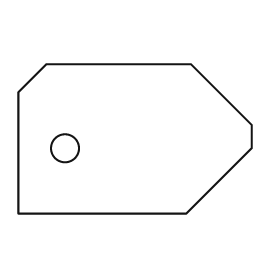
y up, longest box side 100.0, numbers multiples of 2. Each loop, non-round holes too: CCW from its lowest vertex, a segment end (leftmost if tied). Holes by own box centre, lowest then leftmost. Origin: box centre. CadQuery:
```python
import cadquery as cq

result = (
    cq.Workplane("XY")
    .moveTo(-50.0, -32.0)
    .lineTo(22.0, -32.0)
    .lineTo(50.0, -4.0)
    .lineTo(50.0, 6.0)
    .lineTo(24.0, 32.0)
    .lineTo(-38.0, 32.0)
    .lineTo(-50.0, 20.0)
    .close()
    .moveTo(-30.0, -4.0)
    .circle(6.0)
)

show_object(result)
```